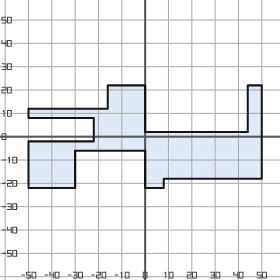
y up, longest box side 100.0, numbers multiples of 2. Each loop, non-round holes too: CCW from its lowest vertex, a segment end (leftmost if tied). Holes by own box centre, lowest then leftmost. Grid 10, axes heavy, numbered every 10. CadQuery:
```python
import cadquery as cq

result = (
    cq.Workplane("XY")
    .moveTo(-50.0, -22.0)
    .lineTo(-30.0, -22.0)
    .lineTo(-30.0, -6.0)
    .lineTo(0.0, -6.0)
    .lineTo(0.0, -22.0)
    .lineTo(8.0, -22.0)
    .lineTo(8.0, -18.0)
    .lineTo(50.0, -18.0)
    .lineTo(50.0, 22.0)
    .lineTo(44.0, 22.0)
    .lineTo(44.0, 2.0)
    .lineTo(0.0, 2.0)
    .lineTo(0.0, 22.0)
    .lineTo(-16.0, 22.0)
    .lineTo(-16.0, 12.0)
    .lineTo(-50.0, 12.0)
    .lineTo(-50.0, 8.0)
    .lineTo(-22.0, 8.0)
    .lineTo(-22.0, -2.0)
    .lineTo(-50.0, -2.0)
    .close()
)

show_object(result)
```